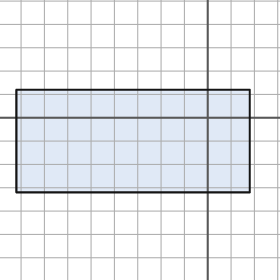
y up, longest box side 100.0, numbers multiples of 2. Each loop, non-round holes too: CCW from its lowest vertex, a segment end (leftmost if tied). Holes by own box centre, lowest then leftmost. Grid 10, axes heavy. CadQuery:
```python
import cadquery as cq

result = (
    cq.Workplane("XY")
    .moveTo(-82.0, -32.0)
    .lineTo(18.0, -32.0)
    .lineTo(18.0, 12.0)
    .lineTo(-82.0, 12.0)
    .close()
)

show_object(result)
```